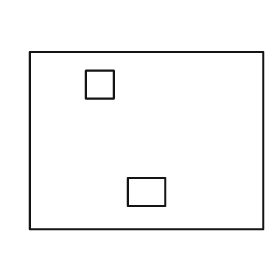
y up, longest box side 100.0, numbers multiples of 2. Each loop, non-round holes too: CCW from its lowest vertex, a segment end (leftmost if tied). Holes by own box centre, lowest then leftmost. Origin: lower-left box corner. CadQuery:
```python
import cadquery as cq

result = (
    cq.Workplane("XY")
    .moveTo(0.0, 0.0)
    .lineTo(100.0, 0.0)
    .lineTo(100.0, 76.0)
    .lineTo(0.0, 76.0)
    .close()
    .moveTo(42.0, 10.0)
    .lineTo(58.0, 10.0)
    .lineTo(58.0, 22.0)
    .lineTo(42.0, 22.0)
    .close()
    .moveTo(24.0, 56.0)
    .lineTo(36.0, 56.0)
    .lineTo(36.0, 68.0)
    .lineTo(24.0, 68.0)
    .close()
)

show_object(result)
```